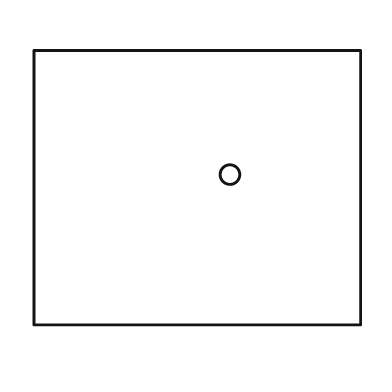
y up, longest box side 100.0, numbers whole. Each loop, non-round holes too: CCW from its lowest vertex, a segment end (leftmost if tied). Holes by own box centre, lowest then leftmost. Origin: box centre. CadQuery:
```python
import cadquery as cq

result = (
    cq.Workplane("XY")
    .moveTo(-50.0, -42.0)
    .lineTo(50.0, -42.0)
    .lineTo(50.0, 42.0)
    .lineTo(-50.0, 42.0)
    .close()
    .moveTo(10.0, 4.0)
    .circle(3.0)
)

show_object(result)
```